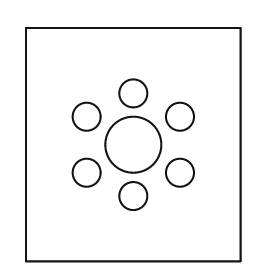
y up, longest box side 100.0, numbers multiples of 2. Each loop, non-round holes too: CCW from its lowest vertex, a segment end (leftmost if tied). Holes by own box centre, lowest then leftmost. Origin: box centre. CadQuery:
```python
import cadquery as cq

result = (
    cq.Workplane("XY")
    .moveTo(-46.0, -50.0)
    .lineTo(46.0, -50.0)
    .lineTo(46.0, 50.0)
    .lineTo(-46.0, 50.0)
    .close()
    .moveTo(0.0, -22.0)
    .circle(6.0)
    .moveTo(-20.0, -12.0)
    .circle(6.0)
    .moveTo(20.0, -12.0)
    .circle(6.0)
    .moveTo(0.0, 0.0)
    .circle(12.0)
    .moveTo(-20.0, 12.0)
    .circle(6.0)
    .moveTo(20.0, 12.0)
    .circle(6.0)
    .moveTo(0.0, 22.0)
    .circle(6.0)
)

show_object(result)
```